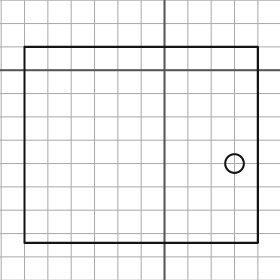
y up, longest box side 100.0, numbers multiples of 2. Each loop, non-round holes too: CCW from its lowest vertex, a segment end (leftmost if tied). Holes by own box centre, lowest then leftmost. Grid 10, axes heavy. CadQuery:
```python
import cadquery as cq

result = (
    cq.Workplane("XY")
    .moveTo(-60.0, -74.0)
    .lineTo(40.0, -74.0)
    .lineTo(40.0, 10.0)
    .lineTo(-60.0, 10.0)
    .close()
    .moveTo(30.0, -40.0)
    .circle(4.0)
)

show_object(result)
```